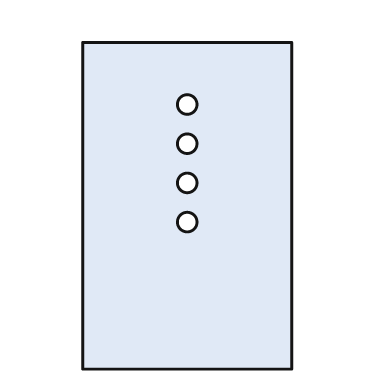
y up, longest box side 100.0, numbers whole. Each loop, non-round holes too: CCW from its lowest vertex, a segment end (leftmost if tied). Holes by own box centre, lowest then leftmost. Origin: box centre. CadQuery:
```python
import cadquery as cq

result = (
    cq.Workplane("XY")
    .moveTo(-32.0, -50.0)
    .lineTo(32.0, -50.0)
    .lineTo(32.0, 50.0)
    .lineTo(-32.0, 50.0)
    .close()
    .moveTo(0.0, -5.0)
    .circle(3.0)
    .moveTo(0.0, 7.0)
    .circle(3.0)
    .moveTo(0.0, 19.0)
    .circle(3.0)
    .moveTo(0.0, 31.0)
    .circle(3.0)
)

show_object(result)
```